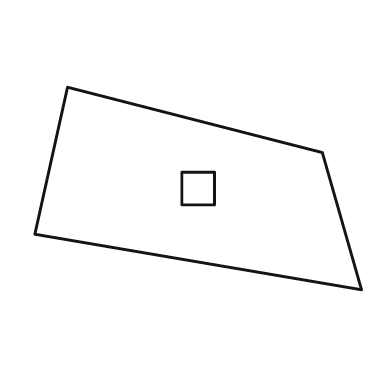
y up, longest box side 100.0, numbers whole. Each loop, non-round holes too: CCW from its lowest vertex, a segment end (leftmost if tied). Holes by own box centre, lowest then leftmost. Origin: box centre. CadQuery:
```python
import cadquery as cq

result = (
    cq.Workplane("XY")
    .moveTo(50.0, -31.0)
    .lineTo(38.0, 11.0)
    .lineTo(-40.0, 31.0)
    .lineTo(-50.0, -14.0)
    .close()
    .moveTo(-5.0, -5.0)
    .lineTo(5.0, -5.0)
    .lineTo(5.0, 5.0)
    .lineTo(-5.0, 5.0)
    .close()
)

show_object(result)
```